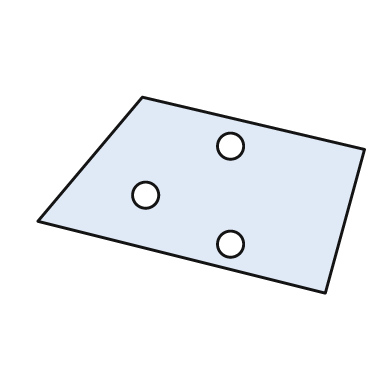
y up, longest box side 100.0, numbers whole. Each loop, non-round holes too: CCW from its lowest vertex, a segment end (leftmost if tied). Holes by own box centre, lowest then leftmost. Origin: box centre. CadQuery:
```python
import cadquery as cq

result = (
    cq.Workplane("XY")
    .moveTo(38.0, -30.0)
    .lineTo(50.0, 14.0)
    .lineTo(-18.0, 30.0)
    .lineTo(-50.0, -8.0)
    .close()
    .moveTo(9.0, -15.0)
    .circle(4.0)
    .moveTo(-17.0, 0.0)
    .circle(4.0)
    .moveTo(9.0, 15.0)
    .circle(4.0)
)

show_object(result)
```